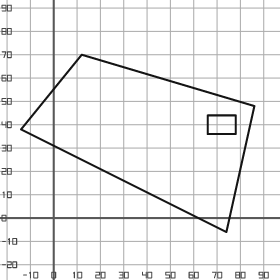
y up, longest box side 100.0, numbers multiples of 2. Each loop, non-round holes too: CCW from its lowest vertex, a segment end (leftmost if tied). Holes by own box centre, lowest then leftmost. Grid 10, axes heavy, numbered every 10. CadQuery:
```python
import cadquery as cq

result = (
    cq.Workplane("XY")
    .moveTo(74.0, -6.0)
    .lineTo(86.0, 48.0)
    .lineTo(12.0, 70.0)
    .lineTo(-14.0, 38.0)
    .close()
    .moveTo(66.0, 36.0)
    .lineTo(78.0, 36.0)
    .lineTo(78.0, 44.0)
    .lineTo(66.0, 44.0)
    .close()
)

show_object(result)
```